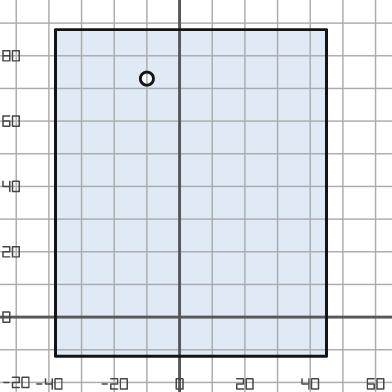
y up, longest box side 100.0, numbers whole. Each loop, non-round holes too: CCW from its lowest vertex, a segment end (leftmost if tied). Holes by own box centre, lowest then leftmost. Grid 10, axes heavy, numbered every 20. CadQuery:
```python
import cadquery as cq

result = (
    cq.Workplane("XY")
    .moveTo(-38.0, -12.0)
    .lineTo(45.0, -12.0)
    .lineTo(45.0, 88.0)
    .lineTo(-38.0, 88.0)
    .close()
    .moveTo(-10.0, 73.0)
    .circle(2.0)
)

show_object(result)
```